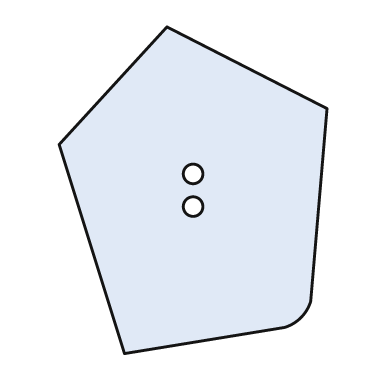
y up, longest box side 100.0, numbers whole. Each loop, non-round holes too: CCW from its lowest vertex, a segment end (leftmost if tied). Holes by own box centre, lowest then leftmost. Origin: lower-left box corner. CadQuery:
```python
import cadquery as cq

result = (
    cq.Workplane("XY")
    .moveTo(20.0, 0.0)
    .lineTo(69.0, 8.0)
    .threePointArc((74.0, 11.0), (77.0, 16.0))
    .lineTo(82.0, 75.0)
    .lineTo(33.0, 100.0)
    .lineTo(0.0, 64.0)
    .close()
    .moveTo(41.0, 45.0)
    .circle(3.0)
    .moveTo(41.0, 55.0)
    .circle(3.0)
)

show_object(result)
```